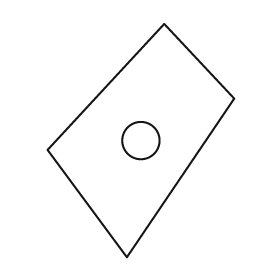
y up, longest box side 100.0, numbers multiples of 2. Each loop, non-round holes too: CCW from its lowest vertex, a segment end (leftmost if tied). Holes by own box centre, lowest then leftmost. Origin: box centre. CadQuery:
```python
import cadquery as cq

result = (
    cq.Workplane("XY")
    .moveTo(-6.0, -50.0)
    .lineTo(40.0, 18.0)
    .lineTo(10.0, 50.0)
    .lineTo(-40.0, -4.0)
    .close()
    .moveTo(0.0, 0.0)
    .circle(8.0)
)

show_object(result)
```